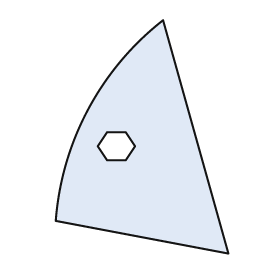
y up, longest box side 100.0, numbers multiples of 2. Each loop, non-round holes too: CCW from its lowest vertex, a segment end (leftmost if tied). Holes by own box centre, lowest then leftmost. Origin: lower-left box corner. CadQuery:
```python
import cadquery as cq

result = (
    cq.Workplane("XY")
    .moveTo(74.0, 0.0)
    .lineTo(46.0, 100.0)
    .threePointArc((14.0, 62.0), (0.0, 14.0))
    .close()
    .moveTo(22.0, 40.0)
    .lineTo(30.0, 40.0)
    .lineTo(34.0, 46.0)
    .lineTo(30.0, 52.0)
    .lineTo(22.0, 52.0)
    .lineTo(18.0, 46.0)
    .close()
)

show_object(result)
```